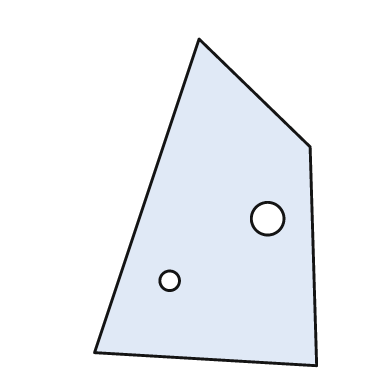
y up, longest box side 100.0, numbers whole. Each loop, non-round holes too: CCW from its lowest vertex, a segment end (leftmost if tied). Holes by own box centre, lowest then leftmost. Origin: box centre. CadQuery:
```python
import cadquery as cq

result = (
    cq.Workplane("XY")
    .moveTo(34.0, -50.0)
    .lineTo(32.0, 17.0)
    .lineTo(-2.0, 50.0)
    .lineTo(-34.0, -46.0)
    .close()
    .moveTo(-11.0, -24.0)
    .circle(3.0)
    .moveTo(19.0, -5.0)
    .circle(5.0)
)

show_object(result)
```